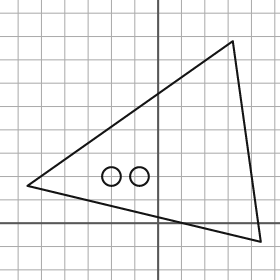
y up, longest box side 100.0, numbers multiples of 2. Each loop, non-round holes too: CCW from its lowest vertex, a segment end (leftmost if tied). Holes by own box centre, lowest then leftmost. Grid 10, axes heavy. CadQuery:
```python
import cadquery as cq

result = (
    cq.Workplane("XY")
    .moveTo(44.0, -8.0)
    .lineTo(32.0, 78.0)
    .lineTo(-56.0, 16.0)
    .close()
    .moveTo(-20.0, 20.0)
    .circle(4.0)
    .moveTo(-8.0, 20.0)
    .circle(4.0)
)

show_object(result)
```